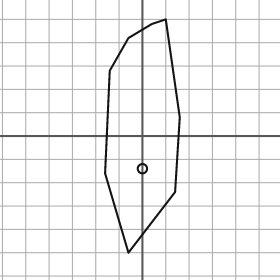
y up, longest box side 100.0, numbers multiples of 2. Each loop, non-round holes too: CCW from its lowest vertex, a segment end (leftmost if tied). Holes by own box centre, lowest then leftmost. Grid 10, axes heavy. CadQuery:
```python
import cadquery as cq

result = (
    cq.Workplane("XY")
    .moveTo(-6.0, -50.0)
    .lineTo(14.0, -24.0)
    .lineTo(16.0, 8.0)
    .lineTo(10.0, 50.0)
    .lineTo(4.0, 48.0)
    .lineTo(-6.0, 42.0)
    .lineTo(-14.0, 28.0)
    .lineTo(-16.0, -16.0)
    .close()
    .moveTo(0.0, -14.0)
    .circle(2.0)
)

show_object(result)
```